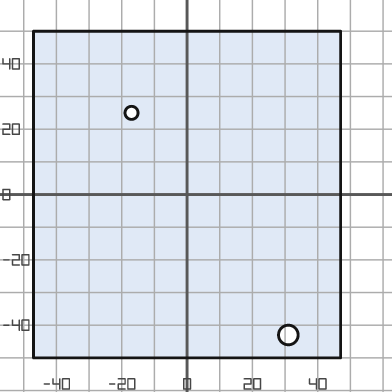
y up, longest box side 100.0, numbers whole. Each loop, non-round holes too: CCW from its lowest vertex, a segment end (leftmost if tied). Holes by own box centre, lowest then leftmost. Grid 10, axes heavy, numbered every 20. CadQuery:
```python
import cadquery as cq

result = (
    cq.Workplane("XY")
    .moveTo(-47.0, -50.0)
    .lineTo(47.0, -50.0)
    .lineTo(47.0, 50.0)
    .lineTo(-47.0, 50.0)
    .close()
    .moveTo(31.0, -43.0)
    .circle(3.0)
    .moveTo(-17.0, 25.0)
    .circle(2.0)
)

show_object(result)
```